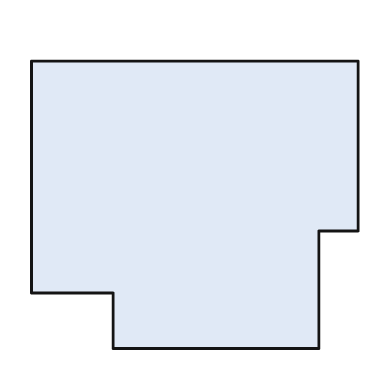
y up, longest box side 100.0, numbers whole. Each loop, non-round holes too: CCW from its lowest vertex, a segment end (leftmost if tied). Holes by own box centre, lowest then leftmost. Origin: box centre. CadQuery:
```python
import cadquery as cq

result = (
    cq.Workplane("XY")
    .moveTo(-25.0, -44.0)
    .lineTo(38.0, -44.0)
    .lineTo(38.0, -8.0)
    .lineTo(50.0, -8.0)
    .lineTo(50.0, 44.0)
    .lineTo(-50.0, 44.0)
    .lineTo(-50.0, -27.0)
    .lineTo(-25.0, -27.0)
    .close()
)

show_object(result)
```